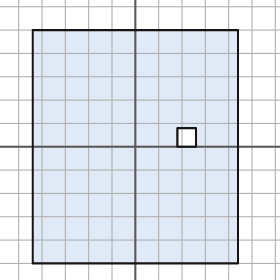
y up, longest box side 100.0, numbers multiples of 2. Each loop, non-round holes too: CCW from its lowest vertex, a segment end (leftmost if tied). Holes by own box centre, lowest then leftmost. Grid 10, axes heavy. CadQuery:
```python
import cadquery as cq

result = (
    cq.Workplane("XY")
    .moveTo(-44.0, -50.0)
    .lineTo(44.0, -50.0)
    .lineTo(44.0, 50.0)
    .lineTo(-44.0, 50.0)
    .close()
    .moveTo(18.0, 0.0)
    .lineTo(26.0, 0.0)
    .lineTo(26.0, 8.0)
    .lineTo(18.0, 8.0)
    .close()
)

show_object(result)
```